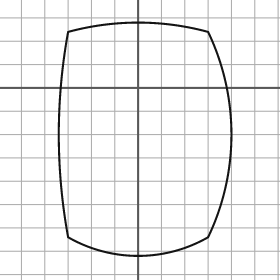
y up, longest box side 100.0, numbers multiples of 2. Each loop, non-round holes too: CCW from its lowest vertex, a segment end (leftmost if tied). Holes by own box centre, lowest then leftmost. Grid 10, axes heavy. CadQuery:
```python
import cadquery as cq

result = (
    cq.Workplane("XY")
    .moveTo(-30.0, -64.0)
    .threePointArc((0.0, -72.0), (30.0, -64.0))
    .threePointArc((40.0, -20.0), (30.0, 24.0))
    .threePointArc((0.0, 28.0), (-30.0, 24.0))
    .threePointArc((-34.0, -20.0), (-30.0, -64.0))
    .close()
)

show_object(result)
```